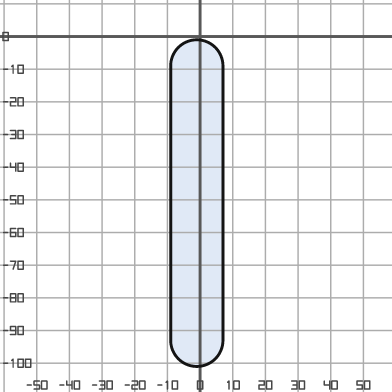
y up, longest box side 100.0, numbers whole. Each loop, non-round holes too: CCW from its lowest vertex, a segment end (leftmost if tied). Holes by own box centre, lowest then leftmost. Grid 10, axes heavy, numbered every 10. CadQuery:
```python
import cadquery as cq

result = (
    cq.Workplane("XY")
    .moveTo(-9.0, -93.0)
    .threePointArc((-1.0, -101.0), (7.0, -93.0))
    .lineTo(7.0, -9.0)
    .threePointArc((-1.0, -1.0), (-9.0, -9.0))
    .close()
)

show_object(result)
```